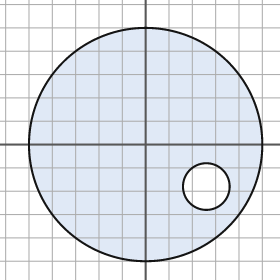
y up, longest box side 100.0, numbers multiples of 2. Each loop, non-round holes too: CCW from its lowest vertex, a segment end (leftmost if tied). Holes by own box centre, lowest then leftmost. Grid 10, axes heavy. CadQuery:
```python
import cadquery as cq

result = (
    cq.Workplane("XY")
    .moveTo(0.0, 0.0)
    .circle(50.0)
    .moveTo(26.0, -18.0)
    .circle(10.0)
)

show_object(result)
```